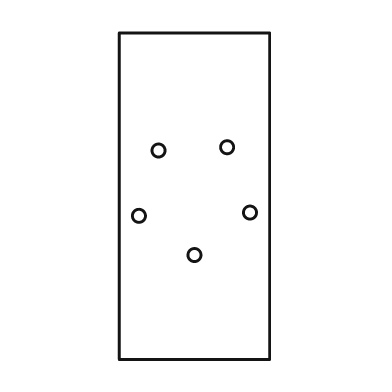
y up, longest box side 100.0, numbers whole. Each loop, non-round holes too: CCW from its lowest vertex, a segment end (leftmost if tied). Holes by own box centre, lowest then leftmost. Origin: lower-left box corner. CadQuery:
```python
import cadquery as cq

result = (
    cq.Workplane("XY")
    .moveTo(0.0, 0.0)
    .lineTo(46.0, 0.0)
    .lineTo(46.0, 100.0)
    .lineTo(0.0, 100.0)
    .close()
    .moveTo(23.0, 32.0)
    .circle(2.0)
    .moveTo(6.0, 44.0)
    .circle(2.0)
    .moveTo(40.0, 45.0)
    .circle(2.0)
    .moveTo(12.0, 64.0)
    .circle(2.0)
    .moveTo(33.0, 65.0)
    .circle(2.0)
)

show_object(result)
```